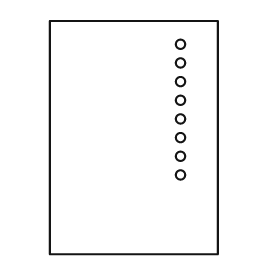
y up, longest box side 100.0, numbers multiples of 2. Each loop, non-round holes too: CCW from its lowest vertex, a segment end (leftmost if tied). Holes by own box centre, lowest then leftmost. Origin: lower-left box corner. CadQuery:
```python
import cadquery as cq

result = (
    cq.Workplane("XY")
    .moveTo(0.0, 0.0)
    .lineTo(72.0, 0.0)
    .lineTo(72.0, 100.0)
    .lineTo(0.0, 100.0)
    .close()
    .moveTo(56.0, 34.0)
    .circle(2.0)
    .moveTo(56.0, 42.0)
    .circle(2.0)
    .moveTo(56.0, 50.0)
    .circle(2.0)
    .moveTo(56.0, 58.0)
    .circle(2.0)
    .moveTo(56.0, 66.0)
    .circle(2.0)
    .moveTo(56.0, 74.0)
    .circle(2.0)
    .moveTo(56.0, 82.0)
    .circle(2.0)
    .moveTo(56.0, 90.0)
    .circle(2.0)
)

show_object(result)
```